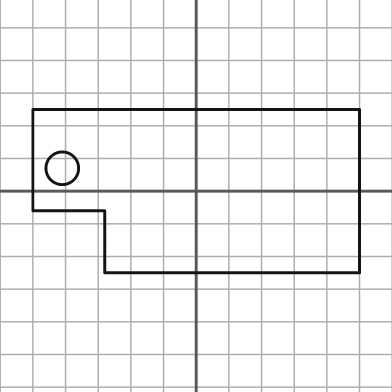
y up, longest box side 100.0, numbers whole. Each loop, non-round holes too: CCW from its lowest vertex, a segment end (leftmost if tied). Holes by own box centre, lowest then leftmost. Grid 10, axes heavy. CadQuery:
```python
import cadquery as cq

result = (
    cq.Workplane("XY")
    .moveTo(-28.0, -25.0)
    .lineTo(50.0, -25.0)
    .lineTo(50.0, 25.0)
    .lineTo(-50.0, 25.0)
    .lineTo(-50.0, -6.0)
    .lineTo(-28.0, -6.0)
    .close()
    .moveTo(-41.0, 7.0)
    .circle(5.0)
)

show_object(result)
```